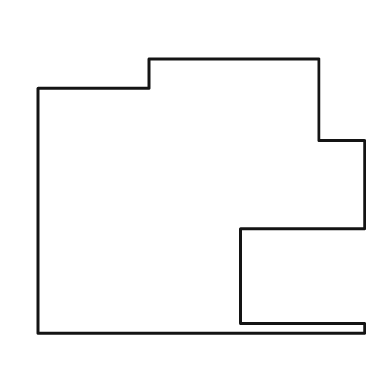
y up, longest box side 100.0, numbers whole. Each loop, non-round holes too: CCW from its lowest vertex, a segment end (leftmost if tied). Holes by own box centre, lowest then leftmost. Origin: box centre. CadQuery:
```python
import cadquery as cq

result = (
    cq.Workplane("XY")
    .moveTo(-50.0, -42.0)
    .lineTo(50.0, -42.0)
    .lineTo(50.0, -39.0)
    .lineTo(12.0, -39.0)
    .lineTo(12.0, -10.0)
    .lineTo(50.0, -10.0)
    .lineTo(50.0, 17.0)
    .lineTo(36.0, 17.0)
    .lineTo(36.0, 42.0)
    .lineTo(-16.0, 42.0)
    .lineTo(-16.0, 33.0)
    .lineTo(-50.0, 33.0)
    .close()
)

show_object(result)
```